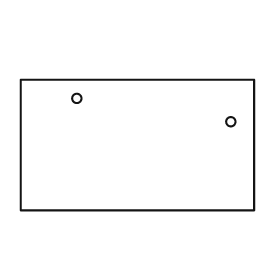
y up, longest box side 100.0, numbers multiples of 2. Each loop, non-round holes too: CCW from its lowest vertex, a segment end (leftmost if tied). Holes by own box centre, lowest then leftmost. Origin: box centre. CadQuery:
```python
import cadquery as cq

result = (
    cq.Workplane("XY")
    .moveTo(-50.0, -28.0)
    .lineTo(50.0, -28.0)
    .lineTo(50.0, 28.0)
    .lineTo(-50.0, 28.0)
    .close()
    .moveTo(40.0, 10.0)
    .circle(2.0)
    .moveTo(-26.0, 20.0)
    .circle(2.0)
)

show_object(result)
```